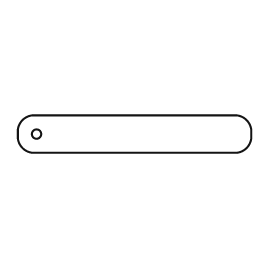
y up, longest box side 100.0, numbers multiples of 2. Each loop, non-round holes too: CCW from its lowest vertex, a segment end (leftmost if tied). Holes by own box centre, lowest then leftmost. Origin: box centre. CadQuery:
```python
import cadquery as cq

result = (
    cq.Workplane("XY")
    .moveTo(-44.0, -8.0)
    .lineTo(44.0, -8.0)
    .threePointArc((48.0, -6.0), (50.0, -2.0))
    .lineTo(50.0, 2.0)
    .threePointArc((48.0, 6.0), (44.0, 8.0))
    .lineTo(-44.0, 8.0)
    .threePointArc((-48.0, 6.0), (-50.0, 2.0))
    .lineTo(-50.0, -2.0)
    .threePointArc((-48.0, -6.0), (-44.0, -8.0))
    .close()
    .moveTo(-42.0, 0.0)
    .circle(2.0)
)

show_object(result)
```